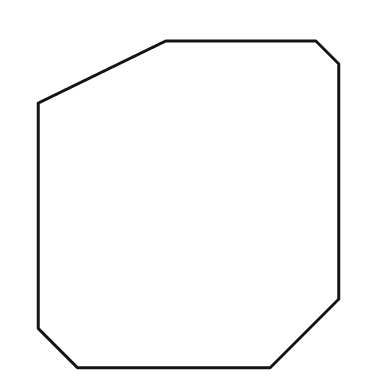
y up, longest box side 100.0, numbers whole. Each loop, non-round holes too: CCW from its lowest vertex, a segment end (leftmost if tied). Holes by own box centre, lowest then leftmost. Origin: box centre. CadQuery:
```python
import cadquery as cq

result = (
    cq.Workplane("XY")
    .moveTo(-34.0, -50.0)
    .lineTo(25.0, -50.0)
    .lineTo(46.0, -29.0)
    .lineTo(46.0, 43.0)
    .lineTo(39.0, 50.0)
    .lineTo(-7.0, 50.0)
    .lineTo(-46.0, 31.0)
    .lineTo(-46.0, -38.0)
    .close()
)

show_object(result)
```